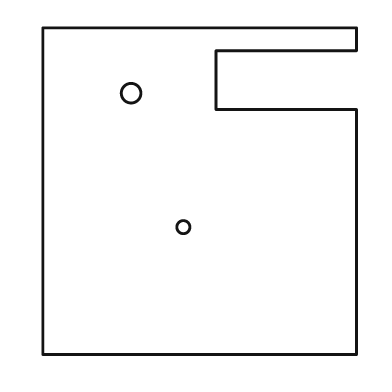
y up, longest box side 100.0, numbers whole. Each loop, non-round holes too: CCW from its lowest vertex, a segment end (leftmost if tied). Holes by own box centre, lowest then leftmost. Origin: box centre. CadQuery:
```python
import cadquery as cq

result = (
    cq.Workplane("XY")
    .moveTo(-48.0, -50.0)
    .lineTo(48.0, -50.0)
    .lineTo(48.0, 25.0)
    .lineTo(5.0, 25.0)
    .lineTo(5.0, 43.0)
    .lineTo(48.0, 43.0)
    .lineTo(48.0, 50.0)
    .lineTo(-48.0, 50.0)
    .close()
    .moveTo(-5.0, -11.0)
    .circle(2.0)
    .moveTo(-21.0, 30.0)
    .circle(3.0)
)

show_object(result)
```